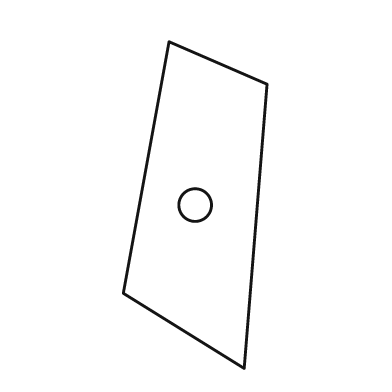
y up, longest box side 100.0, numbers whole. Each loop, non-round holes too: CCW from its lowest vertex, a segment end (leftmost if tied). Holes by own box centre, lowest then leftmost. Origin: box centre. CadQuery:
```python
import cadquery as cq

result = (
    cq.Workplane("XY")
    .moveTo(15.0, -50.0)
    .lineTo(22.0, 37.0)
    .lineTo(-8.0, 50.0)
    .lineTo(-22.0, -27.0)
    .close()
    .moveTo(0.0, 0.0)
    .circle(5.0)
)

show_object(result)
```